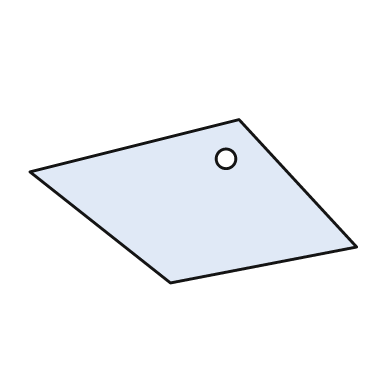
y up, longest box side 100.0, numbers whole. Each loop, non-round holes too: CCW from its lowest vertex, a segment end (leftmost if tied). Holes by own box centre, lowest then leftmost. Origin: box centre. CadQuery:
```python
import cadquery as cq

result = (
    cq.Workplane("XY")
    .moveTo(-7.0, -25.0)
    .lineTo(50.0, -14.0)
    .lineTo(14.0, 25.0)
    .lineTo(-50.0, 9.0)
    .close()
    .moveTo(10.0, 13.0)
    .circle(3.0)
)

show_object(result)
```